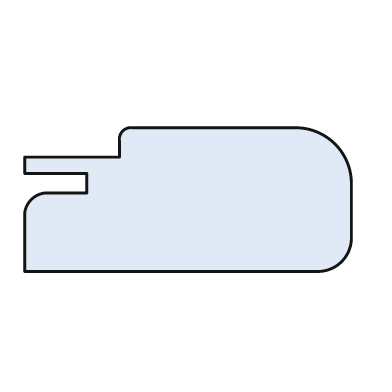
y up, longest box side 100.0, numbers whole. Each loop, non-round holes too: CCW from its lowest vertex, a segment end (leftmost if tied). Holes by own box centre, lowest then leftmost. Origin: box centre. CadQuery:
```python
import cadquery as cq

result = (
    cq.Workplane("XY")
    .moveTo(-50.0, -22.0)
    .lineTo(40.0, -22.0)
    .threePointArc((47.0, -19.0), (50.0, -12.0))
    .lineTo(50.0, 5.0)
    .threePointArc((45.0, 17.0), (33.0, 22.0))
    .lineTo(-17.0, 22.0)
    .threePointArc((-20.0, 21.0), (-21.0, 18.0))
    .lineTo(-21.0, 13.0)
    .lineTo(-50.0, 13.0)
    .lineTo(-50.0, 8.0)
    .lineTo(-31.0, 8.0)
    .lineTo(-31.0, 2.0)
    .lineTo(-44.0, 2.0)
    .threePointArc((-48.0, 0.0), (-50.0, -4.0))
    .close()
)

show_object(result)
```